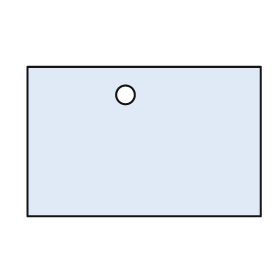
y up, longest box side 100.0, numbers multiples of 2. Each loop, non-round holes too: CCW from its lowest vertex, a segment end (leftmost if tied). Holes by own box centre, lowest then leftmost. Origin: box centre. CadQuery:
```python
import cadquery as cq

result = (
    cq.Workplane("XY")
    .moveTo(-50.0, -32.0)
    .lineTo(50.0, -32.0)
    .lineTo(50.0, 32.0)
    .lineTo(-50.0, 32.0)
    .close()
    .moveTo(-8.0, 20.0)
    .circle(4.0)
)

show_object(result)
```